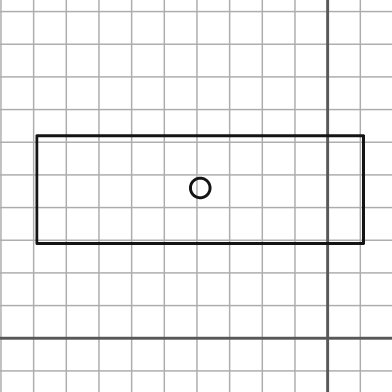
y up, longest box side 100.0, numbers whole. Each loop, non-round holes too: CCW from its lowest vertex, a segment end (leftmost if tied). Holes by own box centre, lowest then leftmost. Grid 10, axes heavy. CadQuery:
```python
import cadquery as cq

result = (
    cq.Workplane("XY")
    .moveTo(-89.0, 29.0)
    .lineTo(11.0, 29.0)
    .lineTo(11.0, 62.0)
    .lineTo(-89.0, 62.0)
    .close()
    .moveTo(-39.0, 46.0)
    .circle(3.0)
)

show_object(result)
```